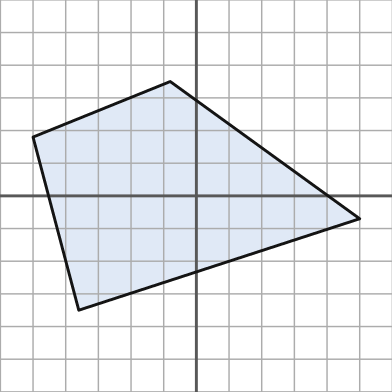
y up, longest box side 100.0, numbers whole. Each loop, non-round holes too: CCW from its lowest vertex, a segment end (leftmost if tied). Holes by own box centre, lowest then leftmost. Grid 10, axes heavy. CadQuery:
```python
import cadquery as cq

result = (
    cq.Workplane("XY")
    .moveTo(-36.0, -35.0)
    .lineTo(50.0, -7.0)
    .lineTo(-8.0, 35.0)
    .lineTo(-50.0, 18.0)
    .close()
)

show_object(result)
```